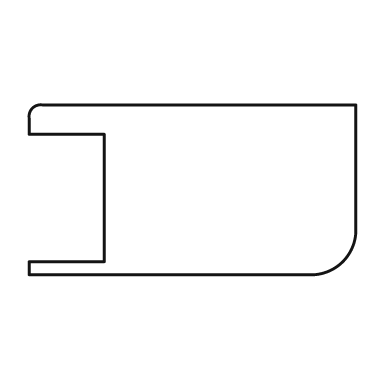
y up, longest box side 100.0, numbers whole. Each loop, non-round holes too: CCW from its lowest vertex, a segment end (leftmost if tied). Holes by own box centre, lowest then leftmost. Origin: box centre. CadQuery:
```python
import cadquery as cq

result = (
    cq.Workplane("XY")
    .moveTo(-50.0, -26.0)
    .lineTo(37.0, -26.0)
    .threePointArc((46.0, -22.0), (50.0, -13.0))
    .lineTo(50.0, 26.0)
    .lineTo(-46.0, 26.0)
    .threePointArc((-49.0, 25.0), (-50.0, 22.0))
    .lineTo(-50.0, 17.0)
    .lineTo(-27.0, 17.0)
    .lineTo(-27.0, -22.0)
    .lineTo(-50.0, -22.0)
    .close()
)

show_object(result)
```